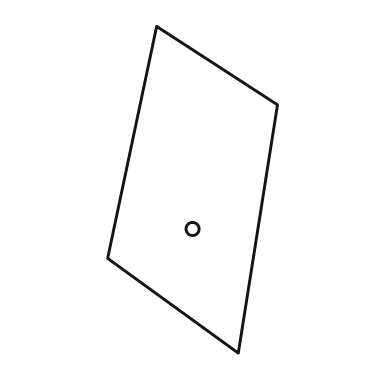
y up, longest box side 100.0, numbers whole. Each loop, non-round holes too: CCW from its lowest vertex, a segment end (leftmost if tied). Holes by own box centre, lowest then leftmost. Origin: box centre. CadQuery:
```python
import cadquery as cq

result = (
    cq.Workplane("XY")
    .moveTo(14.0, -50.0)
    .lineTo(26.0, 26.0)
    .lineTo(-11.0, 50.0)
    .lineTo(-26.0, -21.0)
    .close()
    .moveTo(0.0, -12.0)
    .circle(2.0)
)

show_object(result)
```